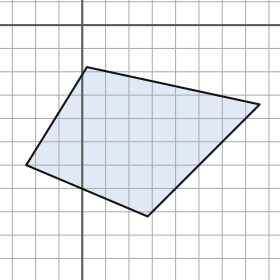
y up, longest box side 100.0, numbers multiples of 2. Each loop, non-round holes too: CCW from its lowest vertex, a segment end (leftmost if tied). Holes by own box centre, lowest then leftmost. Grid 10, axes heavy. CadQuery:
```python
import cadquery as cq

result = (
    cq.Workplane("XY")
    .moveTo(28.0, -82.0)
    .lineTo(76.0, -34.0)
    .lineTo(2.0, -18.0)
    .lineTo(-24.0, -60.0)
    .close()
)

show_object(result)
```